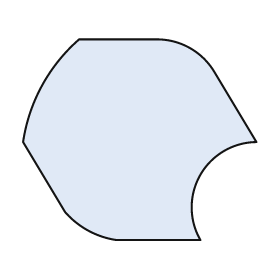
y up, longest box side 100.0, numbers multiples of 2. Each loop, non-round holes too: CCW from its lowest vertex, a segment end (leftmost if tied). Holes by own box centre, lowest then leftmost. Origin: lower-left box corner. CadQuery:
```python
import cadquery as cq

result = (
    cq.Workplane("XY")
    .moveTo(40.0, 0.0)
    .lineTo(76.0, 0.0)
    .threePointArc((76.0, 28.0), (100.0, 42.0))
    .lineTo(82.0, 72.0)
    .threePointArc((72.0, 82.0), (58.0, 86.0))
    .lineTo(24.0, 86.0)
    .threePointArc((8.0, 66.0), (0.0, 42.0))
    .lineTo(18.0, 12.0)
    .threePointArc((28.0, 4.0), (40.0, 0.0))
    .close()
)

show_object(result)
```